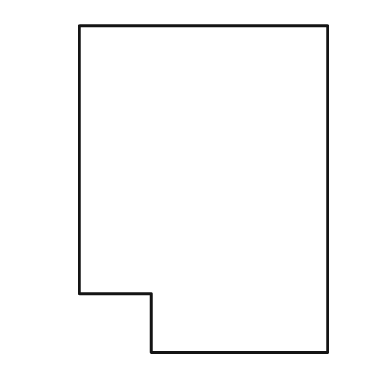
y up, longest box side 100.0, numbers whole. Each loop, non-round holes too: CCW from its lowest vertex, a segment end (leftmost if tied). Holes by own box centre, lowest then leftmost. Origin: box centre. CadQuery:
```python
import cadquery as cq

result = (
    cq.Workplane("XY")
    .moveTo(-16.0, -50.0)
    .lineTo(38.0, -50.0)
    .lineTo(38.0, 50.0)
    .lineTo(-38.0, 50.0)
    .lineTo(-38.0, -32.0)
    .lineTo(-16.0, -32.0)
    .close()
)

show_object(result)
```